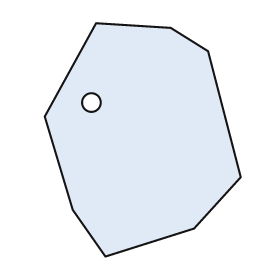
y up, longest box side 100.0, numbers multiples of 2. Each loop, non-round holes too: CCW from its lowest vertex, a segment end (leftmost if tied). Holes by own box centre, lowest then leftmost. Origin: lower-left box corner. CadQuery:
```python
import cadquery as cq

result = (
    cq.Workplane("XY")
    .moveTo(26.0, 0.0)
    .lineTo(64.0, 12.0)
    .lineTo(84.0, 34.0)
    .lineTo(70.0, 88.0)
    .lineTo(54.0, 98.0)
    .lineTo(22.0, 100.0)
    .lineTo(0.0, 60.0)
    .lineTo(12.0, 20.0)
    .close()
    .moveTo(20.0, 66.0)
    .circle(4.0)
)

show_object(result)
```